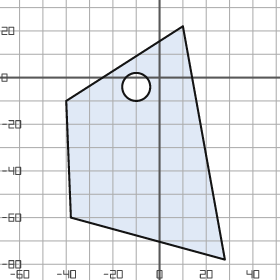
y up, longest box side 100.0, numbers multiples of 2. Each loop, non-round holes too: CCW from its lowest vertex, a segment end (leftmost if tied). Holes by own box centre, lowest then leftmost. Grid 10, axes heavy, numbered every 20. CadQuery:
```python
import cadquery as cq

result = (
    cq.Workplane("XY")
    .moveTo(28.0, -78.0)
    .lineTo(10.0, 22.0)
    .lineTo(-40.0, -10.0)
    .lineTo(-38.0, -60.0)
    .close()
    .moveTo(-10.0, -4.0)
    .circle(6.0)
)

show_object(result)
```